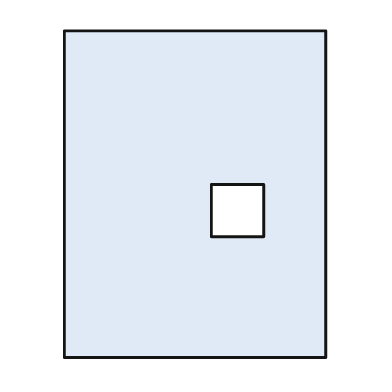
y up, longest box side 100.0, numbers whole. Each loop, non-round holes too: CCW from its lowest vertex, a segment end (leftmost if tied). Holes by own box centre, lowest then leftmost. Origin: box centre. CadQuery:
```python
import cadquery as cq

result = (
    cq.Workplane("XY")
    .moveTo(-40.0, -50.0)
    .lineTo(40.0, -50.0)
    .lineTo(40.0, 50.0)
    .lineTo(-40.0, 50.0)
    .close()
    .moveTo(5.0, -13.0)
    .lineTo(21.0, -13.0)
    .lineTo(21.0, 3.0)
    .lineTo(5.0, 3.0)
    .close()
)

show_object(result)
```